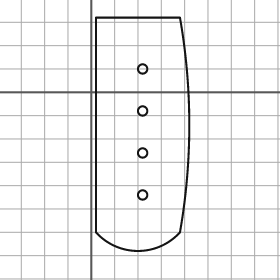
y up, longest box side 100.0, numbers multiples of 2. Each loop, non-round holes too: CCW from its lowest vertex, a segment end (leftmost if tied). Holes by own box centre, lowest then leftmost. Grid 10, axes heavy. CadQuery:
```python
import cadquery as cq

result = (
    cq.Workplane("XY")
    .moveTo(2.0, -60.0)
    .threePointArc((20.0, -68.0), (38.0, -60.0))
    .threePointArc((42.0, -14.0), (38.0, 32.0))
    .lineTo(2.0, 32.0)
    .close()
    .moveTo(22.0, -44.0)
    .circle(2.0)
    .moveTo(22.0, -26.0)
    .circle(2.0)
    .moveTo(22.0, -8.0)
    .circle(2.0)
    .moveTo(22.0, 10.0)
    .circle(2.0)
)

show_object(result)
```